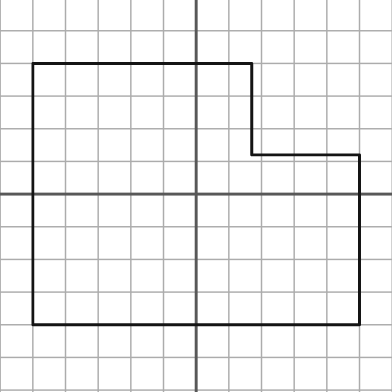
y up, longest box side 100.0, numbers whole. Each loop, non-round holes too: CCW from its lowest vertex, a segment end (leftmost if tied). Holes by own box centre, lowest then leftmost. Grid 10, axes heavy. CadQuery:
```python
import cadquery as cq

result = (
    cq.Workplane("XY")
    .moveTo(-50.0, -40.0)
    .lineTo(50.0, -40.0)
    .lineTo(50.0, 12.0)
    .lineTo(17.0, 12.0)
    .lineTo(17.0, 40.0)
    .lineTo(-50.0, 40.0)
    .close()
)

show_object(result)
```